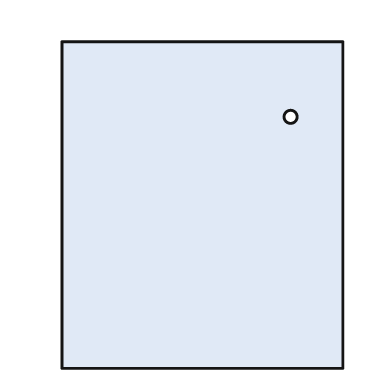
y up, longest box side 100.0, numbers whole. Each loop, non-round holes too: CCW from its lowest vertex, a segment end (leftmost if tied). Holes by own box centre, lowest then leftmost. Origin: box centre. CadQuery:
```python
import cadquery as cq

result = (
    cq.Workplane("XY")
    .moveTo(-43.0, -50.0)
    .lineTo(43.0, -50.0)
    .lineTo(43.0, 50.0)
    .lineTo(-43.0, 50.0)
    .close()
    .moveTo(27.0, 27.0)
    .circle(2.0)
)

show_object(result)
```